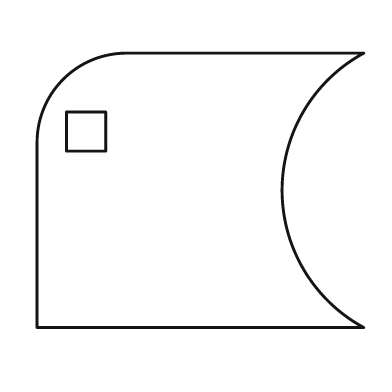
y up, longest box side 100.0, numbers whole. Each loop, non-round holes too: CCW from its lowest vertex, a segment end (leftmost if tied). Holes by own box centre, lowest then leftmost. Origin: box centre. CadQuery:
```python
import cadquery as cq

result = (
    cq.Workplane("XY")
    .moveTo(-50.0, -42.0)
    .lineTo(50.0, -42.0)
    .threePointArc((25.0, 0.0), (50.0, 42.0))
    .lineTo(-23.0, 42.0)
    .threePointArc((-42.0, 34.0), (-50.0, 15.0))
    .close()
    .moveTo(-41.0, 12.0)
    .lineTo(-29.0, 12.0)
    .lineTo(-29.0, 24.0)
    .lineTo(-41.0, 24.0)
    .close()
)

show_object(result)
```